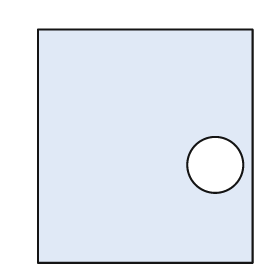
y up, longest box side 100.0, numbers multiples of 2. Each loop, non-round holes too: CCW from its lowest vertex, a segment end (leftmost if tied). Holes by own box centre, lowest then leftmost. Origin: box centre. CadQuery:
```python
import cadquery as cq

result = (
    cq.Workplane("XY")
    .moveTo(-46.0, -50.0)
    .lineTo(46.0, -50.0)
    .lineTo(46.0, 50.0)
    .lineTo(-46.0, 50.0)
    .close()
    .moveTo(30.0, -8.0)
    .circle(12.0)
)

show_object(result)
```